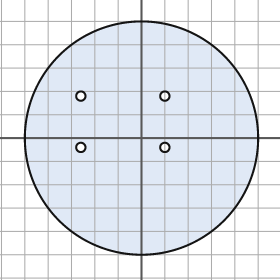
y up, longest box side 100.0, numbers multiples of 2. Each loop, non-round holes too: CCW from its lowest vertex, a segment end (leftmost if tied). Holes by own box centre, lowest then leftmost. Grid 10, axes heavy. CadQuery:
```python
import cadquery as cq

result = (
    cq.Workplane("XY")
    .moveTo(0.0, 0.0)
    .circle(50.0)
    .moveTo(-26.0, -4.0)
    .circle(2.0)
    .moveTo(10.0, -4.0)
    .circle(2.0)
    .moveTo(-26.0, 18.0)
    .circle(2.0)
    .moveTo(10.0, 18.0)
    .circle(2.0)
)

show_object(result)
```